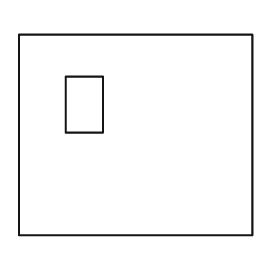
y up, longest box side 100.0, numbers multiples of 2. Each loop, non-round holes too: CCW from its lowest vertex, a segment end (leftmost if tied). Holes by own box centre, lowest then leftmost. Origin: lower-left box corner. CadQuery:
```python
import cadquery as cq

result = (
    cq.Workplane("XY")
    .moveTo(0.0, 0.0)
    .lineTo(100.0, 0.0)
    .lineTo(100.0, 86.0)
    .lineTo(0.0, 86.0)
    .close()
    .moveTo(20.0, 44.0)
    .lineTo(36.0, 44.0)
    .lineTo(36.0, 68.0)
    .lineTo(20.0, 68.0)
    .close()
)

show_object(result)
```